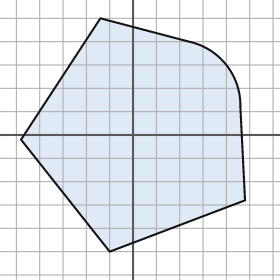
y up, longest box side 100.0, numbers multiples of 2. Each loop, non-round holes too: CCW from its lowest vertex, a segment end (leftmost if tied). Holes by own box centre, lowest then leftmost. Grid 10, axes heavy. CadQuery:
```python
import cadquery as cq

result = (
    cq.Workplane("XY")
    .moveTo(-10.0, -50.0)
    .lineTo(48.0, -28.0)
    .lineTo(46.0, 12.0)
    .threePointArc((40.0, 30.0), (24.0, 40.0))
    .lineTo(-14.0, 50.0)
    .lineTo(-48.0, -2.0)
    .close()
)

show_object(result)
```